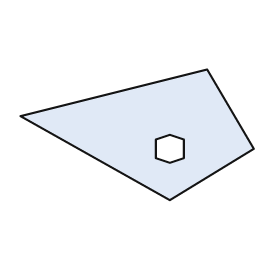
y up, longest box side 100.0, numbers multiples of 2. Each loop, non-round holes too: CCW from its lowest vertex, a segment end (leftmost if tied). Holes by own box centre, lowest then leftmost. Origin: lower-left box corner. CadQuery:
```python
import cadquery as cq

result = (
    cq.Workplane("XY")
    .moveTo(64.0, 0.0)
    .lineTo(100.0, 22.0)
    .lineTo(80.0, 56.0)
    .lineTo(0.0, 36.0)
    .close()
    .moveTo(64.0, 16.0)
    .lineTo(70.0, 18.0)
    .lineTo(70.0, 26.0)
    .lineTo(64.0, 28.0)
    .lineTo(58.0, 26.0)
    .lineTo(58.0, 18.0)
    .close()
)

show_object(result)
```